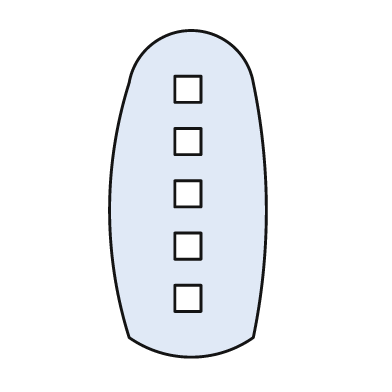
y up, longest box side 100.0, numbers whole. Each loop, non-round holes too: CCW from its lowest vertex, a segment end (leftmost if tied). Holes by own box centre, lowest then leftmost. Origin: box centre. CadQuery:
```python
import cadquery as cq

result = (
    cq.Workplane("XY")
    .moveTo(-18.0, -44.0)
    .threePointArc((1.0, -50.0), (20.0, -44.0))
    .threePointArc((24.0, -5.0), (20.0, 34.0))
    .threePointArc((1.0, 50.0), (-18.0, 34.0))
    .threePointArc((-24.0, -5.0), (-18.0, -44.0))
    .close()
    .moveTo(-4.0, -36.0)
    .lineTo(4.0, -36.0)
    .lineTo(4.0, -28.0)
    .lineTo(-4.0, -28.0)
    .close()
    .moveTo(-4.0, -20.0)
    .lineTo(4.0, -20.0)
    .lineTo(4.0, -12.0)
    .lineTo(-4.0, -12.0)
    .close()
    .moveTo(-4.0, -4.0)
    .lineTo(4.0, -4.0)
    .lineTo(4.0, 4.0)
    .lineTo(-4.0, 4.0)
    .close()
    .moveTo(-4.0, 12.0)
    .lineTo(4.0, 12.0)
    .lineTo(4.0, 20.0)
    .lineTo(-4.0, 20.0)
    .close()
    .moveTo(-4.0, 28.0)
    .lineTo(4.0, 28.0)
    .lineTo(4.0, 36.0)
    .lineTo(-4.0, 36.0)
    .close()
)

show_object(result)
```